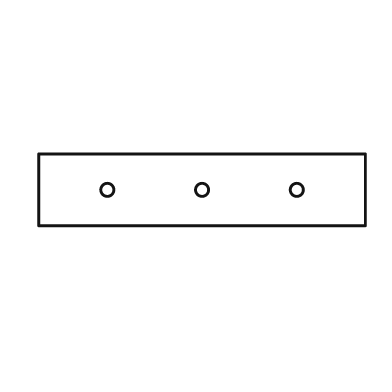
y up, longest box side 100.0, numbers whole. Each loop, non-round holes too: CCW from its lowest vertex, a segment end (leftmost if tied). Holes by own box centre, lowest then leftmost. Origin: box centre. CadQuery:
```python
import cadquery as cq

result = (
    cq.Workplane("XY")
    .moveTo(-50.0, -11.0)
    .lineTo(50.0, -11.0)
    .lineTo(50.0, 11.0)
    .lineTo(-50.0, 11.0)
    .close()
    .moveTo(-29.0, 0.0)
    .circle(2.0)
    .moveTo(0.0, 0.0)
    .circle(2.0)
    .moveTo(29.0, 0.0)
    .circle(2.0)
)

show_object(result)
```